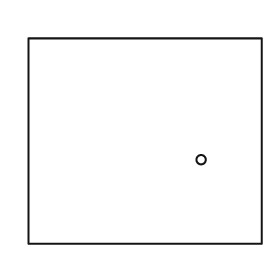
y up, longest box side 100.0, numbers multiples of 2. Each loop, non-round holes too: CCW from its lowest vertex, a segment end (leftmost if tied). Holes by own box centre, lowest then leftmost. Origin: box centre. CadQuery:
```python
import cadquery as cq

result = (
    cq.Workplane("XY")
    .moveTo(-50.0, -44.0)
    .lineTo(50.0, -44.0)
    .lineTo(50.0, 44.0)
    .lineTo(-50.0, 44.0)
    .close()
    .moveTo(24.0, -8.0)
    .circle(2.0)
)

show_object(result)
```